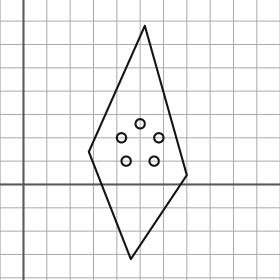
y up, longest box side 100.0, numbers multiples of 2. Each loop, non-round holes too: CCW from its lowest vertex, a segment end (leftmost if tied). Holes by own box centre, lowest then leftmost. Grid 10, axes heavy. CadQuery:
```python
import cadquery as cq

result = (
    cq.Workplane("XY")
    .moveTo(46.0, -32.0)
    .lineTo(70.0, 4.0)
    .lineTo(52.0, 68.0)
    .lineTo(28.0, 14.0)
    .close()
    .moveTo(44.0, 10.0)
    .circle(2.0)
    .moveTo(56.0, 10.0)
    .circle(2.0)
    .moveTo(42.0, 20.0)
    .circle(2.0)
    .moveTo(58.0, 20.0)
    .circle(2.0)
    .moveTo(50.0, 26.0)
    .circle(2.0)
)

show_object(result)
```